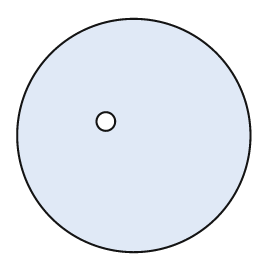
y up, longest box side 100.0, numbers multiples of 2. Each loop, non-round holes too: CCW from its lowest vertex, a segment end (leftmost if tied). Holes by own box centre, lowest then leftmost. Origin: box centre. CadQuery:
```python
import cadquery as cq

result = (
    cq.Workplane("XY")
    .moveTo(0.0, 0.0)
    .circle(50.0)
    .moveTo(-12.0, 6.0)
    .circle(4.0)
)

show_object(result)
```